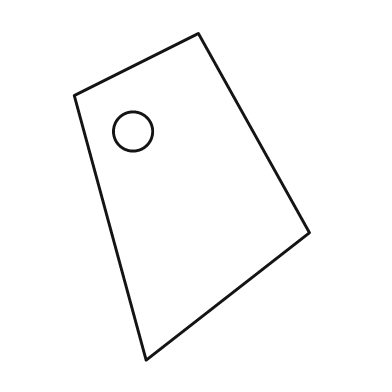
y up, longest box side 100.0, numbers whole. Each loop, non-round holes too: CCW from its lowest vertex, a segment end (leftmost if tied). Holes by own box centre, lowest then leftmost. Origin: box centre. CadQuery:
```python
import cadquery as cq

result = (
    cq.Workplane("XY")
    .moveTo(-14.0, -50.0)
    .lineTo(36.0, -11.0)
    .lineTo(2.0, 50.0)
    .lineTo(-36.0, 31.0)
    .close()
    .moveTo(-18.0, 20.0)
    .circle(6.0)
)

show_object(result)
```